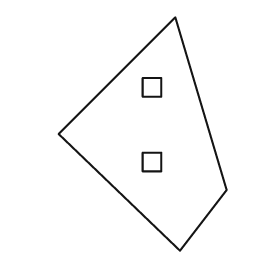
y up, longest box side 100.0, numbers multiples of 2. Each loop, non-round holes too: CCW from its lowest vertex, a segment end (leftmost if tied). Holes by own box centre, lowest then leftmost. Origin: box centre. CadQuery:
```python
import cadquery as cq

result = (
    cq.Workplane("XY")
    .moveTo(16.0, -50.0)
    .lineTo(36.0, -24.0)
    .lineTo(14.0, 50.0)
    .lineTo(-36.0, 0.0)
    .close()
    .moveTo(0.0, -16.0)
    .lineTo(8.0, -16.0)
    .lineTo(8.0, -8.0)
    .lineTo(0.0, -8.0)
    .close()
    .moveTo(0.0, 16.0)
    .lineTo(8.0, 16.0)
    .lineTo(8.0, 24.0)
    .lineTo(0.0, 24.0)
    .close()
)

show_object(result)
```